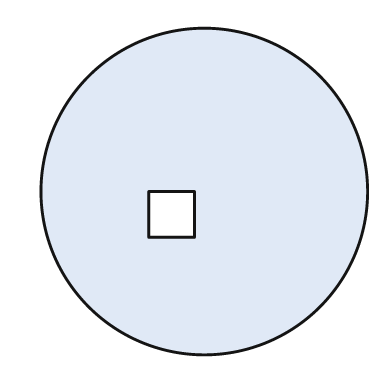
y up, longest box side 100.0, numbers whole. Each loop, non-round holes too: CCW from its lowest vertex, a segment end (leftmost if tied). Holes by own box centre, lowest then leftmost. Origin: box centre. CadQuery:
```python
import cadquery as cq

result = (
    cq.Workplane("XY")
    .moveTo(0.0, 0.0)
    .circle(50.0)
    .moveTo(-17.0, -14.0)
    .lineTo(-3.0, -14.0)
    .lineTo(-3.0, 0.0)
    .lineTo(-17.0, 0.0)
    .close()
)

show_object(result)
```